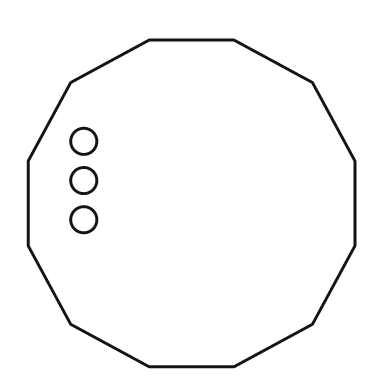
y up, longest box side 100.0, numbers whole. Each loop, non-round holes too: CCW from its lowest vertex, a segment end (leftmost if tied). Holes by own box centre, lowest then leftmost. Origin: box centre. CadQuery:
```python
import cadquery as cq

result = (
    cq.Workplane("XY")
    .moveTo(-13.0, -50.0)
    .lineTo(13.0, -50.0)
    .lineTo(37.0, -37.0)
    .lineTo(50.0, -13.0)
    .lineTo(50.0, 13.0)
    .lineTo(37.0, 37.0)
    .lineTo(13.0, 50.0)
    .lineTo(-13.0, 50.0)
    .lineTo(-37.0, 37.0)
    .lineTo(-50.0, 13.0)
    .lineTo(-50.0, -13.0)
    .lineTo(-37.0, -37.0)
    .close()
    .moveTo(-33.0, -5.0)
    .circle(4.0)
    .moveTo(-33.0, 7.0)
    .circle(4.0)
    .moveTo(-33.0, 19.0)
    .circle(4.0)
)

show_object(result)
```